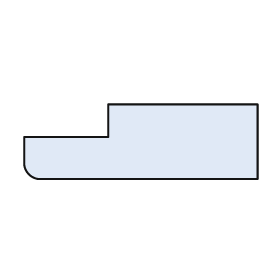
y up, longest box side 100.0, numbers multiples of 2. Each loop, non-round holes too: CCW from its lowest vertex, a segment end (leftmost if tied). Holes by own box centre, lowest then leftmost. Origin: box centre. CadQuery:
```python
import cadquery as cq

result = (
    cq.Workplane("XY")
    .moveTo(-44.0, -16.0)
    .lineTo(50.0, -16.0)
    .lineTo(50.0, 16.0)
    .lineTo(-14.0, 16.0)
    .lineTo(-14.0, 2.0)
    .lineTo(-50.0, 2.0)
    .lineTo(-50.0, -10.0)
    .threePointArc((-48.0, -14.0), (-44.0, -16.0))
    .close()
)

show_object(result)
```